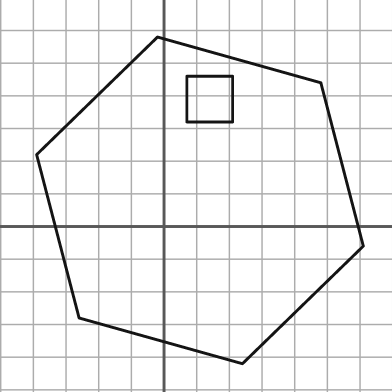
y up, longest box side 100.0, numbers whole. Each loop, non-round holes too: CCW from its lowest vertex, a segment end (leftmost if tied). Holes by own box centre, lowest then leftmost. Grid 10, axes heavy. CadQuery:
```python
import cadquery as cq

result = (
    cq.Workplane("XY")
    .moveTo(24.0, -42.0)
    .lineTo(61.0, -6.0)
    .lineTo(48.0, 44.0)
    .lineTo(-2.0, 58.0)
    .lineTo(-39.0, 22.0)
    .lineTo(-26.0, -28.0)
    .close()
    .moveTo(7.0, 32.0)
    .lineTo(21.0, 32.0)
    .lineTo(21.0, 46.0)
    .lineTo(7.0, 46.0)
    .close()
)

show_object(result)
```